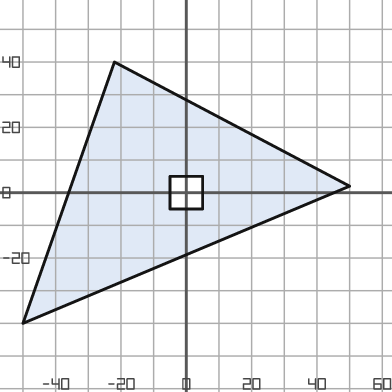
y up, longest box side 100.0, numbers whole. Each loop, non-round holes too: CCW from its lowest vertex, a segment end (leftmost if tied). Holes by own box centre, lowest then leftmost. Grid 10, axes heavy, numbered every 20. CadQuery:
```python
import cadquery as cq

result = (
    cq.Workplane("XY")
    .moveTo(-50.0, -40.0)
    .lineTo(50.0, 2.0)
    .lineTo(-22.0, 40.0)
    .close()
    .moveTo(-5.0, -5.0)
    .lineTo(5.0, -5.0)
    .lineTo(5.0, 5.0)
    .lineTo(-5.0, 5.0)
    .close()
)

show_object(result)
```